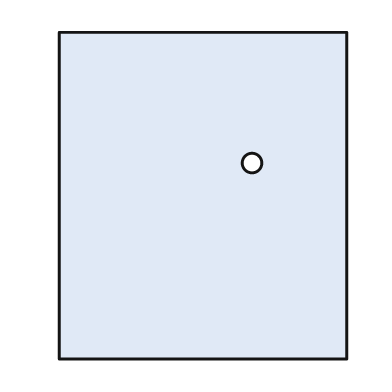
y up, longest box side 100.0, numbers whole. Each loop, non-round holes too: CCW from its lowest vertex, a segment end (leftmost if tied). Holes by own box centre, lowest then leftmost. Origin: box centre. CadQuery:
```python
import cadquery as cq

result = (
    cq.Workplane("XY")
    .moveTo(-44.0, -50.0)
    .lineTo(44.0, -50.0)
    .lineTo(44.0, 50.0)
    .lineTo(-44.0, 50.0)
    .close()
    .moveTo(15.0, 10.0)
    .circle(3.0)
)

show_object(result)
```